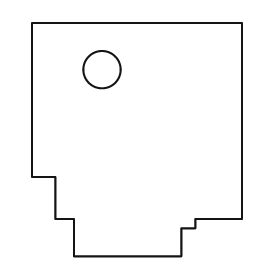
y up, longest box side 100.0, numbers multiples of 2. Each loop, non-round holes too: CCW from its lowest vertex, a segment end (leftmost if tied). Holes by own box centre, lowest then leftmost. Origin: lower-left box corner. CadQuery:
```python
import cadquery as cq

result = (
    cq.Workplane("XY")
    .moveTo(18.0, 0.0)
    .lineTo(64.0, 0.0)
    .lineTo(64.0, 12.0)
    .lineTo(70.0, 12.0)
    .lineTo(70.0, 16.0)
    .lineTo(90.0, 16.0)
    .lineTo(90.0, 100.0)
    .lineTo(0.0, 100.0)
    .lineTo(0.0, 34.0)
    .lineTo(10.0, 34.0)
    .lineTo(10.0, 16.0)
    .lineTo(18.0, 16.0)
    .close()
    .moveTo(30.0, 80.0)
    .circle(8.0)
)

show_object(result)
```